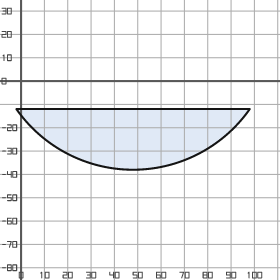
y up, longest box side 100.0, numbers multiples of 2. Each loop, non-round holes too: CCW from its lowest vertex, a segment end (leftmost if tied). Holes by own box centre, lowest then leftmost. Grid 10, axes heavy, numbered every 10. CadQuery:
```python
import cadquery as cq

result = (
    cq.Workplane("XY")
    .moveTo(-2.0, -12.0)
    .threePointArc((48.0, -38.0), (98.0, -12.0))
    .close()
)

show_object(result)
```